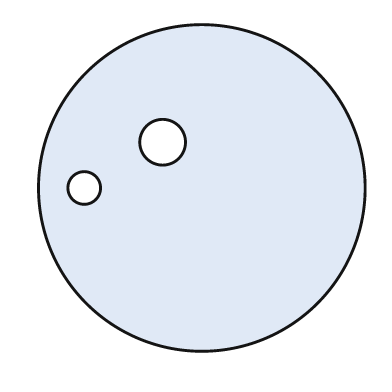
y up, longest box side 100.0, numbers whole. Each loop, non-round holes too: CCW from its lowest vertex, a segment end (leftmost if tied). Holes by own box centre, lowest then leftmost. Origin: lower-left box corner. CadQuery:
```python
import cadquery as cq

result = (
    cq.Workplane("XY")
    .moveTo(50.0, 50.0)
    .circle(50.0)
    .moveTo(14.0, 50.0)
    .circle(5.0)
    .moveTo(38.0, 64.0)
    .circle(7.0)
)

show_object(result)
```